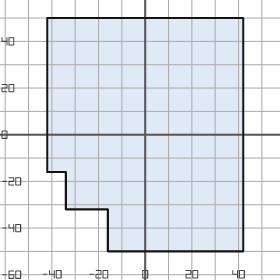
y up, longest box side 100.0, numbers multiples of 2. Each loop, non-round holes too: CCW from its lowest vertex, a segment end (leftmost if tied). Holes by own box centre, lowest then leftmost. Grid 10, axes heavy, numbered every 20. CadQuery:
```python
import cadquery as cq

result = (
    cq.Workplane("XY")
    .moveTo(-16.0, -50.0)
    .lineTo(42.0, -50.0)
    .lineTo(42.0, 50.0)
    .lineTo(-42.0, 50.0)
    .lineTo(-42.0, -16.0)
    .lineTo(-34.0, -16.0)
    .lineTo(-34.0, -32.0)
    .lineTo(-16.0, -32.0)
    .close()
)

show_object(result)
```